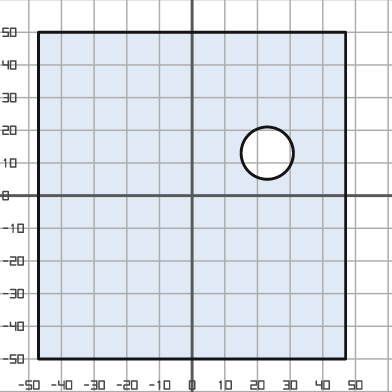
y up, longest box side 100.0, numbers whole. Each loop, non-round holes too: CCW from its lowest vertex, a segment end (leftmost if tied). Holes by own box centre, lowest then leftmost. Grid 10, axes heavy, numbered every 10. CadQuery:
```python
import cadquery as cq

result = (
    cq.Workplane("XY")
    .moveTo(-47.0, -50.0)
    .lineTo(47.0, -50.0)
    .lineTo(47.0, 50.0)
    .lineTo(-47.0, 50.0)
    .close()
    .moveTo(23.0, 13.0)
    .circle(8.0)
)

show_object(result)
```